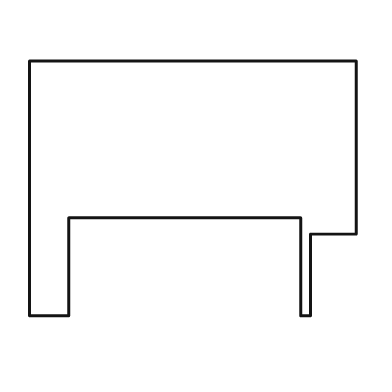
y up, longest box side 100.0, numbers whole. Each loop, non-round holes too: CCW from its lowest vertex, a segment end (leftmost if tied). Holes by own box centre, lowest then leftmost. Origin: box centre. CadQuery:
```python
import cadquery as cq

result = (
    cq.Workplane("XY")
    .moveTo(-50.0, -39.0)
    .lineTo(-38.0, -39.0)
    .lineTo(-38.0, -9.0)
    .lineTo(33.0, -9.0)
    .lineTo(33.0, -39.0)
    .lineTo(36.0, -39.0)
    .lineTo(36.0, -14.0)
    .lineTo(50.0, -14.0)
    .lineTo(50.0, 39.0)
    .lineTo(-50.0, 39.0)
    .close()
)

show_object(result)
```